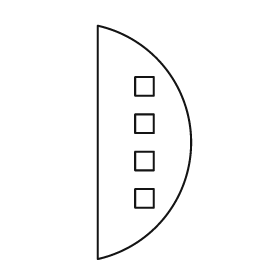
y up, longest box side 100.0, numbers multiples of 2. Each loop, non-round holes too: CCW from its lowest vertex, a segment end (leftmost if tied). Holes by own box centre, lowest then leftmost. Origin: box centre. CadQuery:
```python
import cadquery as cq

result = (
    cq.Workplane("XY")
    .moveTo(-20.0, -50.0)
    .threePointArc((20.0, 0.0), (-20.0, 50.0))
    .close()
    .moveTo(-4.0, -28.0)
    .lineTo(4.0, -28.0)
    .lineTo(4.0, -20.0)
    .lineTo(-4.0, -20.0)
    .close()
    .moveTo(-4.0, -12.0)
    .lineTo(4.0, -12.0)
    .lineTo(4.0, -4.0)
    .lineTo(-4.0, -4.0)
    .close()
    .moveTo(-4.0, 4.0)
    .lineTo(4.0, 4.0)
    .lineTo(4.0, 12.0)
    .lineTo(-4.0, 12.0)
    .close()
    .moveTo(-4.0, 20.0)
    .lineTo(4.0, 20.0)
    .lineTo(4.0, 28.0)
    .lineTo(-4.0, 28.0)
    .close()
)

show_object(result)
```